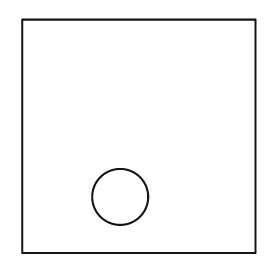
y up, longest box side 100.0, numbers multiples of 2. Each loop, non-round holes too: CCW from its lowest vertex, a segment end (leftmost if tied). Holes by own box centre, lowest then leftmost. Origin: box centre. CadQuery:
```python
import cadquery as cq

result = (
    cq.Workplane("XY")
    .moveTo(-50.0, -50.0)
    .lineTo(50.0, -50.0)
    .lineTo(50.0, 50.0)
    .lineTo(-50.0, 50.0)
    .close()
    .moveTo(-8.0, -26.0)
    .circle(12.0)
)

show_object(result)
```